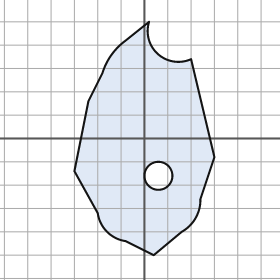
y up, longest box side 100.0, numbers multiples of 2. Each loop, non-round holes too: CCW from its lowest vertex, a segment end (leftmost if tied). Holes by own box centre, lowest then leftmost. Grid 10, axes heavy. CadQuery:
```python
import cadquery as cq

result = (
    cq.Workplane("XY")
    .moveTo(4.0, -50.0)
    .lineTo(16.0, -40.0)
    .threePointArc((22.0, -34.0), (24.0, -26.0))
    .lineTo(30.0, -8.0)
    .lineTo(20.0, 34.0)
    .threePointArc((6.0, 36.0), (2.0, 50.0))
    .lineTo(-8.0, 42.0)
    .threePointArc((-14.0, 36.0), (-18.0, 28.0))
    .lineTo(-24.0, 16.0)
    .lineTo(-30.0, -14.0)
    .lineTo(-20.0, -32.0)
    .threePointArc((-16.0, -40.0), (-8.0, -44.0))
    .close()
    .moveTo(6.0, -16.0)
    .circle(6.0)
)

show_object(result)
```